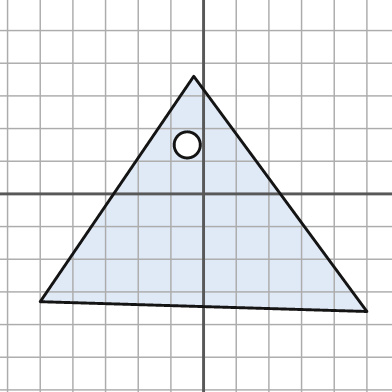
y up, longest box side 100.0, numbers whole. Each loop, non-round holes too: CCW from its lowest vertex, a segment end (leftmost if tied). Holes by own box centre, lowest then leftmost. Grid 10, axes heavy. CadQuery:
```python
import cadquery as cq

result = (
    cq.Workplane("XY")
    .moveTo(50.0, -36.0)
    .lineTo(-3.0, 36.0)
    .lineTo(-50.0, -33.0)
    .close()
    .moveTo(-5.0, 15.0)
    .circle(4.0)
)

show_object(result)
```